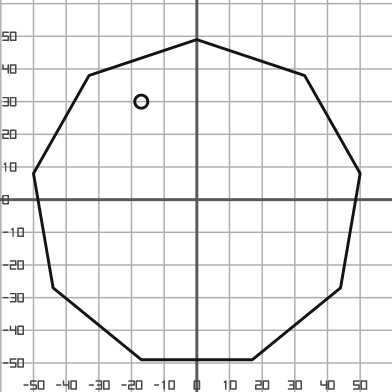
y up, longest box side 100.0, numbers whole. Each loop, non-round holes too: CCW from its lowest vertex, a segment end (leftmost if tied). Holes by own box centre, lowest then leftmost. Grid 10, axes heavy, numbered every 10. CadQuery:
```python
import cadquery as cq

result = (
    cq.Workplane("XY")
    .moveTo(-17.0, -49.0)
    .lineTo(17.0, -49.0)
    .lineTo(44.0, -27.0)
    .lineTo(50.0, 8.0)
    .lineTo(33.0, 38.0)
    .lineTo(0.0, 49.0)
    .lineTo(-33.0, 38.0)
    .lineTo(-50.0, 8.0)
    .lineTo(-44.0, -27.0)
    .close()
    .moveTo(-17.0, 30.0)
    .circle(2.0)
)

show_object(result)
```